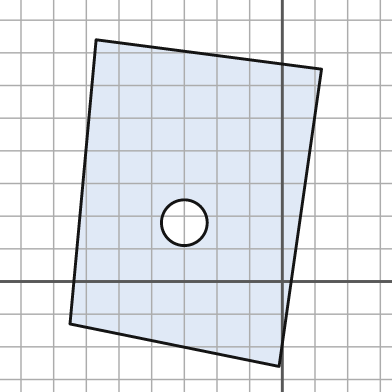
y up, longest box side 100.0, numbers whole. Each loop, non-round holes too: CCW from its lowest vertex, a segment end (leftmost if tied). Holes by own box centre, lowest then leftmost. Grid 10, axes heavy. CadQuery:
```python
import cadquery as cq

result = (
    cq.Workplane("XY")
    .moveTo(-1.0, -26.0)
    .lineTo(12.0, 65.0)
    .lineTo(-57.0, 74.0)
    .lineTo(-65.0, -13.0)
    .close()
    .moveTo(-30.0, 18.0)
    .circle(7.0)
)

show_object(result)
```